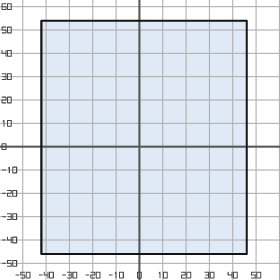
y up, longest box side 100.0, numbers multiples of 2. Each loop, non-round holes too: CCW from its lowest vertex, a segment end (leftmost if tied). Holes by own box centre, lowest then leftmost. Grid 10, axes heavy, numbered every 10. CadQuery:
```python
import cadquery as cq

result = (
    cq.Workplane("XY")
    .moveTo(-42.0, -46.0)
    .lineTo(46.0, -46.0)
    .lineTo(46.0, 54.0)
    .lineTo(-42.0, 54.0)
    .close()
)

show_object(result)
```